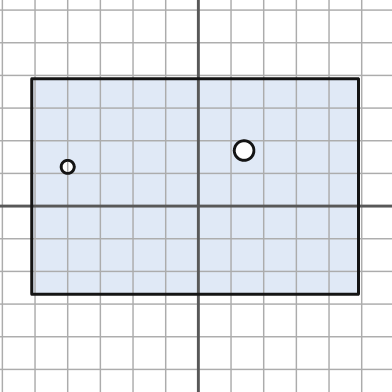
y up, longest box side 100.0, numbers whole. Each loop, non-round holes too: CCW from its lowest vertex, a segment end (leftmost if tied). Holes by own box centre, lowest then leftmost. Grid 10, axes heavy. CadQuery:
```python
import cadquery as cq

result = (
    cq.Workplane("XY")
    .moveTo(-51.0, -27.0)
    .lineTo(49.0, -27.0)
    .lineTo(49.0, 39.0)
    .lineTo(-51.0, 39.0)
    .close()
    .moveTo(-40.0, 12.0)
    .circle(2.0)
    .moveTo(14.0, 17.0)
    .circle(3.0)
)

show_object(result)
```